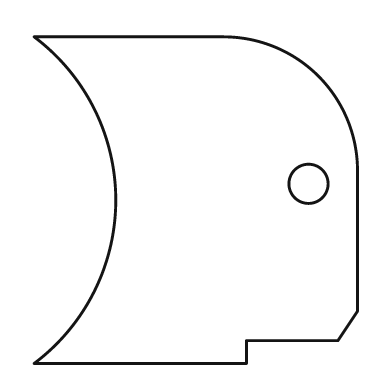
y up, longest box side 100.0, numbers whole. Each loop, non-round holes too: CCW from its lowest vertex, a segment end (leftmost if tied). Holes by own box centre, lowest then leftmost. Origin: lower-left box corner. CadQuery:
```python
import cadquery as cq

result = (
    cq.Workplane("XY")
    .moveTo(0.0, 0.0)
    .lineTo(65.0, 0.0)
    .lineTo(65.0, 7.0)
    .lineTo(93.0, 7.0)
    .lineTo(99.0, 16.0)
    .lineTo(99.0, 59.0)
    .threePointArc((87.0, 88.0), (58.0, 100.0))
    .lineTo(0.0, 100.0)
    .threePointArc((25.0, 50.0), (0.0, 0.0))
    .close()
    .moveTo(84.0, 55.0)
    .circle(6.0)
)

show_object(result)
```